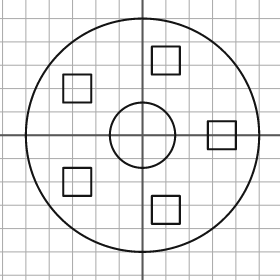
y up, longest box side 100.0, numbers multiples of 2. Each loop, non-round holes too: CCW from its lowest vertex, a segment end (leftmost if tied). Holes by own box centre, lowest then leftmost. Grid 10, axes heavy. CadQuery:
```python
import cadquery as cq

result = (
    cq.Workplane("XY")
    .moveTo(0.0, 0.0)
    .circle(50.0)
    .moveTo(4.0, -38.0)
    .lineTo(16.0, -38.0)
    .lineTo(16.0, -26.0)
    .lineTo(4.0, -26.0)
    .close()
    .moveTo(-34.0, -26.0)
    .lineTo(-22.0, -26.0)
    .lineTo(-22.0, -14.0)
    .lineTo(-34.0, -14.0)
    .close()
    .moveTo(0.0, 0.0)
    .circle(14.0)
    .moveTo(28.0, -6.0)
    .lineTo(40.0, -6.0)
    .lineTo(40.0, 6.0)
    .lineTo(28.0, 6.0)
    .close()
    .moveTo(-34.0, 14.0)
    .lineTo(-22.0, 14.0)
    .lineTo(-22.0, 26.0)
    .lineTo(-34.0, 26.0)
    .close()
    .moveTo(4.0, 26.0)
    .lineTo(16.0, 26.0)
    .lineTo(16.0, 38.0)
    .lineTo(4.0, 38.0)
    .close()
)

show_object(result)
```